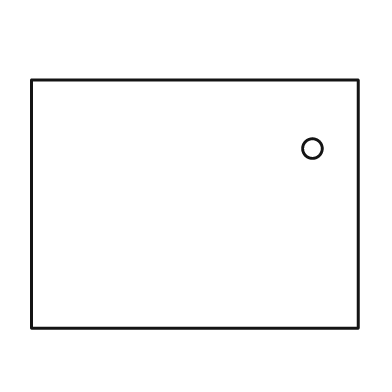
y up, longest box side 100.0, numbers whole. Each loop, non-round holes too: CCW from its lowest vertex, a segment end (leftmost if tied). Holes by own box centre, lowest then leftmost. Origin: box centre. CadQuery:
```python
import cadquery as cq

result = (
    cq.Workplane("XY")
    .moveTo(-50.0, -38.0)
    .lineTo(50.0, -38.0)
    .lineTo(50.0, 38.0)
    .lineTo(-50.0, 38.0)
    .close()
    .moveTo(36.0, 17.0)
    .circle(3.0)
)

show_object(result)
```